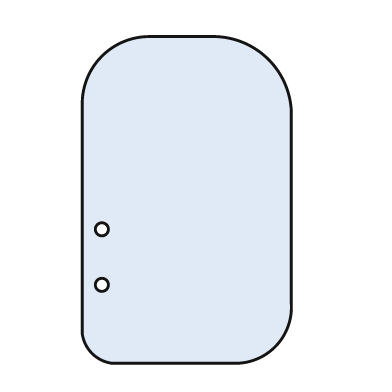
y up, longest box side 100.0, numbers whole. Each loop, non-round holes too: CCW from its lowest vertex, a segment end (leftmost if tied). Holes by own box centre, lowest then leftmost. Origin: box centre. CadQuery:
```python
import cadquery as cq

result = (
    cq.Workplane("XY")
    .moveTo(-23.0, -50.0)
    .lineTo(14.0, -50.0)
    .threePointArc((27.0, -45.0), (32.0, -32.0))
    .lineTo(32.0, 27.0)
    .threePointArc((25.0, 43.0), (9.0, 50.0))
    .lineTo(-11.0, 50.0)
    .threePointArc((-26.0, 44.0), (-32.0, 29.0))
    .lineTo(-32.0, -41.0)
    .threePointArc((-29.0, -47.0), (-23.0, -50.0))
    .close()
    .moveTo(-26.0, -26.0)
    .circle(2.0)
    .moveTo(-26.0, -9.0)
    .circle(2.0)
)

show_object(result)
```